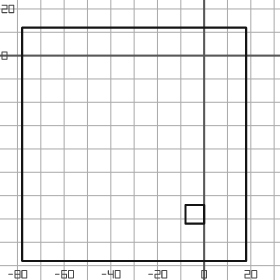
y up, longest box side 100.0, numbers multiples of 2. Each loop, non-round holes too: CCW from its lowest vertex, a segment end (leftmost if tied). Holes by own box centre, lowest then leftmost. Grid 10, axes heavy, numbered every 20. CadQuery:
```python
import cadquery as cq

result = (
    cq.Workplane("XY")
    .moveTo(-78.0, -88.0)
    .lineTo(18.0, -88.0)
    .lineTo(18.0, 12.0)
    .lineTo(-78.0, 12.0)
    .close()
    .moveTo(-8.0, -72.0)
    .lineTo(0.0, -72.0)
    .lineTo(0.0, -64.0)
    .lineTo(-8.0, -64.0)
    .close()
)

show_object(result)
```